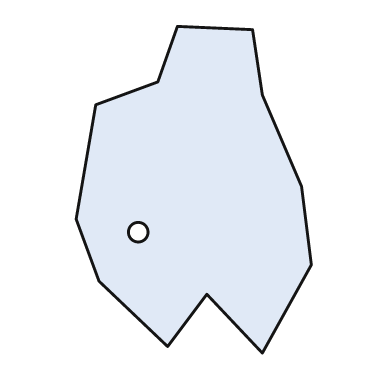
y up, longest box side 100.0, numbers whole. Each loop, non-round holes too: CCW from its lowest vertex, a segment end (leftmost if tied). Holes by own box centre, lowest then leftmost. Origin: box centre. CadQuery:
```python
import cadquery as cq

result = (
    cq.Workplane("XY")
    .moveTo(21.0, -50.0)
    .lineTo(36.0, -23.0)
    .lineTo(33.0, 1.0)
    .lineTo(21.0, 29.0)
    .lineTo(18.0, 49.0)
    .lineTo(-5.0, 50.0)
    .lineTo(-11.0, 33.0)
    .lineTo(-30.0, 26.0)
    .lineTo(-36.0, -9.0)
    .lineTo(-29.0, -28.0)
    .lineTo(-8.0, -48.0)
    .lineTo(4.0, -32.0)
    .close()
    .moveTo(-17.0, -13.0)
    .circle(3.0)
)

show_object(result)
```